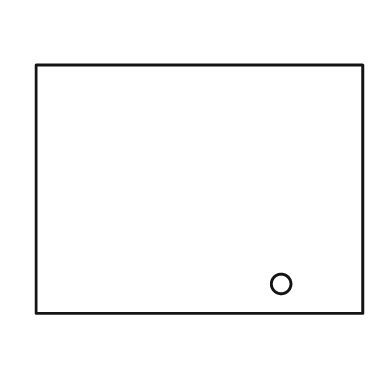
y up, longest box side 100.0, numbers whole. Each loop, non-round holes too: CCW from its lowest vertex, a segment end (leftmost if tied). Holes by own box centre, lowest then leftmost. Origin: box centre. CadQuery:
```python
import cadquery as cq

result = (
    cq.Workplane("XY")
    .moveTo(-50.0, -38.0)
    .lineTo(50.0, -38.0)
    .lineTo(50.0, 38.0)
    .lineTo(-50.0, 38.0)
    .close()
    .moveTo(25.0, -29.0)
    .circle(3.0)
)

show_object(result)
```